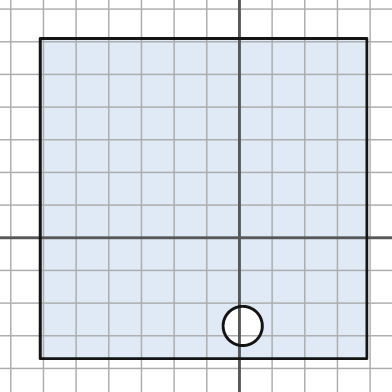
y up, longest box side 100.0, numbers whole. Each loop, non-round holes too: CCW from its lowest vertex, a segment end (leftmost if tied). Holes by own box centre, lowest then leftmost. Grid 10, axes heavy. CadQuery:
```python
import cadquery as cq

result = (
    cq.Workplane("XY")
    .moveTo(-61.0, -37.0)
    .lineTo(39.0, -37.0)
    .lineTo(39.0, 61.0)
    .lineTo(-61.0, 61.0)
    .close()
    .moveTo(1.0, -27.0)
    .circle(6.0)
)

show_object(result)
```